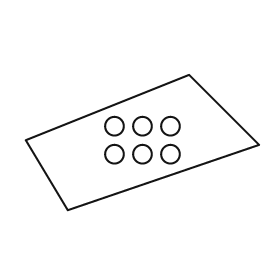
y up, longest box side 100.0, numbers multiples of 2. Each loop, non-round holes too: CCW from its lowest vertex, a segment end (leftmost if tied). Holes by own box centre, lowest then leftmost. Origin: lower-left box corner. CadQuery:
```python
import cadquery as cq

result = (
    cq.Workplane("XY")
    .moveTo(18.0, 0.0)
    .lineTo(100.0, 28.0)
    .lineTo(70.0, 58.0)
    .lineTo(0.0, 30.0)
    .close()
    .moveTo(38.0, 24.0)
    .circle(4.0)
    .moveTo(50.0, 24.0)
    .circle(4.0)
    .moveTo(62.0, 24.0)
    .circle(4.0)
    .moveTo(38.0, 36.0)
    .circle(4.0)
    .moveTo(50.0, 36.0)
    .circle(4.0)
    .moveTo(62.0, 36.0)
    .circle(4.0)
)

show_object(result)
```